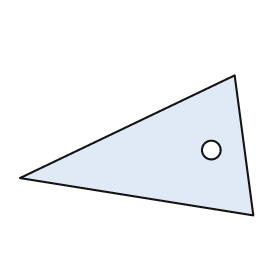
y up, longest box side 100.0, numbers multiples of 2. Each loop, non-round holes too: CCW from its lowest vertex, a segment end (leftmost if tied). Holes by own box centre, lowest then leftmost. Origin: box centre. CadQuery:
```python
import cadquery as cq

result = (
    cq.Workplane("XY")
    .moveTo(50.0, -30.0)
    .lineTo(42.0, 30.0)
    .lineTo(-50.0, -14.0)
    .close()
    .moveTo(32.0, -2.0)
    .circle(4.0)
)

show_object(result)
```